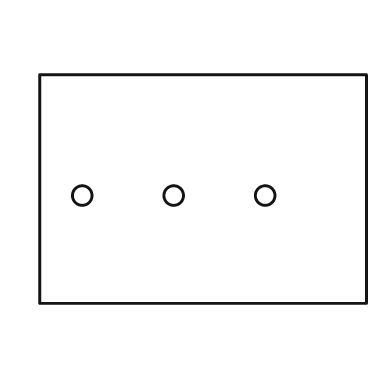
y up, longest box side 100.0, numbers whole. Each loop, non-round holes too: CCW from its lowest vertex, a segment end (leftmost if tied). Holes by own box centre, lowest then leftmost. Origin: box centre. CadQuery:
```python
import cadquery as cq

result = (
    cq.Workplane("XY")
    .moveTo(-50.0, -35.0)
    .lineTo(50.0, -35.0)
    .lineTo(50.0, 35.0)
    .lineTo(-50.0, 35.0)
    .close()
    .moveTo(-37.0, -2.0)
    .circle(3.0)
    .moveTo(-9.0, -2.0)
    .circle(3.0)
    .moveTo(19.0, -2.0)
    .circle(3.0)
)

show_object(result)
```